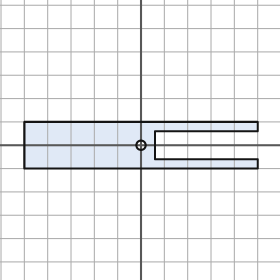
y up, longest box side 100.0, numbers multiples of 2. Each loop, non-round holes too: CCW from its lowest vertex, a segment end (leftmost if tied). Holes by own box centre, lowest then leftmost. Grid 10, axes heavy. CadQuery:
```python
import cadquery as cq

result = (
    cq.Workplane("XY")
    .moveTo(-50.0, -10.0)
    .lineTo(50.0, -10.0)
    .lineTo(50.0, -6.0)
    .lineTo(6.0, -6.0)
    .lineTo(6.0, 6.0)
    .lineTo(50.0, 6.0)
    .lineTo(50.0, 10.0)
    .lineTo(-50.0, 10.0)
    .close()
    .moveTo(0.0, 0.0)
    .circle(2.0)
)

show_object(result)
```